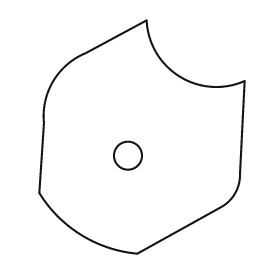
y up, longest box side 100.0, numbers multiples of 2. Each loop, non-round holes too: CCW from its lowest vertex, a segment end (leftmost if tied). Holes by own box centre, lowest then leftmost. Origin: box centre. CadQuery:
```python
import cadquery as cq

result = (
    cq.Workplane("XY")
    .moveTo(-2.0, -50.0)
    .lineTo(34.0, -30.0)
    .threePointArc((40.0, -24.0), (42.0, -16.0))
    .lineTo(44.0, 24.0)
    .threePointArc((16.0, 26.0), (2.0, 50.0))
    .lineTo(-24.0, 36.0)
    .threePointArc((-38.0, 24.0), (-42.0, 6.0))
    .lineTo(-44.0, -24.0)
    .threePointArc((-26.0, -42.0), (-2.0, -50.0))
    .close()
    .moveTo(-6.0, -8.0)
    .circle(6.0)
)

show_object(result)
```